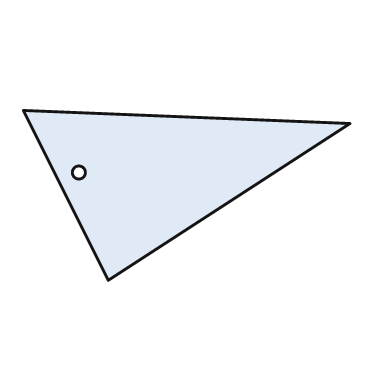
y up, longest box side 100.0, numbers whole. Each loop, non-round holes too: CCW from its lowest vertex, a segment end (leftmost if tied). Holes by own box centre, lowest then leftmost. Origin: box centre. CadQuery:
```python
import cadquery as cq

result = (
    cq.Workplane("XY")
    .moveTo(-24.0, -26.0)
    .lineTo(50.0, 22.0)
    .lineTo(-50.0, 26.0)
    .close()
    .moveTo(-33.0, 7.0)
    .circle(2.0)
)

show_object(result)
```